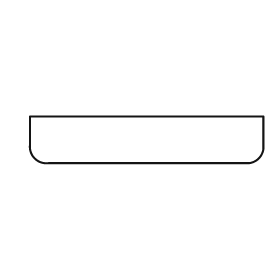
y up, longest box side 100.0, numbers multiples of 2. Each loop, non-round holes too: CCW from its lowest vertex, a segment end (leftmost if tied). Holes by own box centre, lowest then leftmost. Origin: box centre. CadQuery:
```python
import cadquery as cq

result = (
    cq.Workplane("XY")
    .moveTo(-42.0, -10.0)
    .lineTo(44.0, -10.0)
    .threePointArc((48.0, -8.0), (50.0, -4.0))
    .lineTo(50.0, 10.0)
    .lineTo(-50.0, 10.0)
    .lineTo(-50.0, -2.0)
    .threePointArc((-48.0, -8.0), (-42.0, -10.0))
    .close()
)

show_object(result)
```